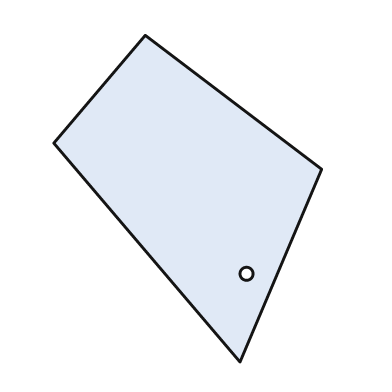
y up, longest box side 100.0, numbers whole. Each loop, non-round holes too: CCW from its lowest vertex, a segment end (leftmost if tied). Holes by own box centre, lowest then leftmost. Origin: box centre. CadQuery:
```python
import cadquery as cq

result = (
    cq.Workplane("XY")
    .moveTo(16.0, -50.0)
    .lineTo(41.0, 9.0)
    .lineTo(-13.0, 50.0)
    .lineTo(-41.0, 17.0)
    .close()
    .moveTo(18.0, -23.0)
    .circle(2.0)
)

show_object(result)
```